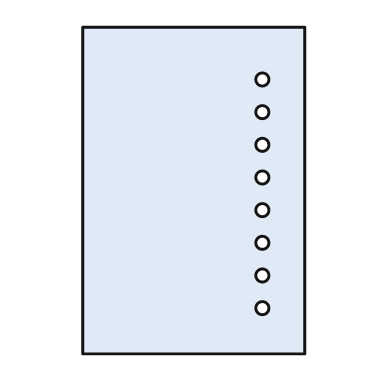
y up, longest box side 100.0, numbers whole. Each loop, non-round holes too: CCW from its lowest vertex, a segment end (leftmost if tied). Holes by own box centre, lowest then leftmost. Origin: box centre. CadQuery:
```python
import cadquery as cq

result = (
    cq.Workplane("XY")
    .moveTo(-34.0, -50.0)
    .lineTo(34.0, -50.0)
    .lineTo(34.0, 50.0)
    .lineTo(-34.0, 50.0)
    .close()
    .moveTo(21.0, -36.0)
    .circle(2.0)
    .moveTo(21.0, -26.0)
    .circle(2.0)
    .moveTo(21.0, -16.0)
    .circle(2.0)
    .moveTo(21.0, -6.0)
    .circle(2.0)
    .moveTo(21.0, 4.0)
    .circle(2.0)
    .moveTo(21.0, 14.0)
    .circle(2.0)
    .moveTo(21.0, 24.0)
    .circle(2.0)
    .moveTo(21.0, 34.0)
    .circle(2.0)
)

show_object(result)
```